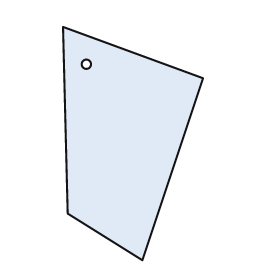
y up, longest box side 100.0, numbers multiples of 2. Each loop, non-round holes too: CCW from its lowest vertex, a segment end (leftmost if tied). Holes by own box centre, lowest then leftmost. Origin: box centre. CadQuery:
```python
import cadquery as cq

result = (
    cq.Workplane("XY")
    .moveTo(4.0, -50.0)
    .lineTo(30.0, 28.0)
    .lineTo(-30.0, 50.0)
    .lineTo(-28.0, -30.0)
    .close()
    .moveTo(-20.0, 34.0)
    .circle(2.0)
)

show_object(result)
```